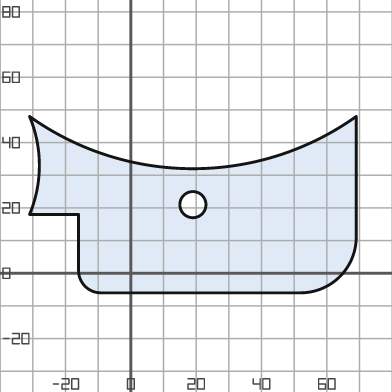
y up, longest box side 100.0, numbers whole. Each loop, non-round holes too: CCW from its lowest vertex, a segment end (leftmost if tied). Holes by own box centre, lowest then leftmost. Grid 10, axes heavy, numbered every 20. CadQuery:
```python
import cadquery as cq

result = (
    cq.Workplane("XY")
    .moveTo(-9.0, -6.0)
    .lineTo(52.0, -6.0)
    .threePointArc((64.0, -1.0), (69.0, 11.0))
    .lineTo(69.0, 48.0)
    .threePointArc((19.0, 32.0), (-31.0, 48.0))
    .threePointArc((-28.0, 33.0), (-31.0, 18.0))
    .lineTo(-16.0, 18.0)
    .lineTo(-16.0, 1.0)
    .threePointArc((-14.0, -4.0), (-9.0, -6.0))
    .close()
    .moveTo(19.0, 21.0)
    .circle(4.0)
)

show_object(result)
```